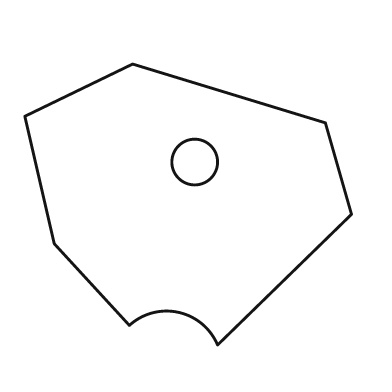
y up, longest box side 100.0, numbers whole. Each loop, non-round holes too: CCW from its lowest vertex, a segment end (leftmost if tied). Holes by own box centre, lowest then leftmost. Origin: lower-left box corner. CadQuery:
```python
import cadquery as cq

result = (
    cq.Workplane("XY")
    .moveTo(59.0, 0.0)
    .lineTo(100.0, 40.0)
    .lineTo(92.0, 68.0)
    .lineTo(33.0, 86.0)
    .lineTo(0.0, 70.0)
    .lineTo(9.0, 31.0)
    .lineTo(32.0, 6.0)
    .threePointArc((47.0, 10.0), (59.0, 0.0))
    .close()
    .moveTo(52.0, 56.0)
    .circle(7.0)
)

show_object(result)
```